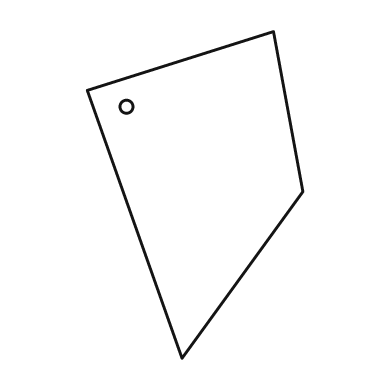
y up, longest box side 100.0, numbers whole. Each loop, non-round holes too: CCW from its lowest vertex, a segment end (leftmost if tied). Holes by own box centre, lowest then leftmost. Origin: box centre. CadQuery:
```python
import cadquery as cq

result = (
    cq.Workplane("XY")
    .moveTo(-4.0, -50.0)
    .lineTo(33.0, 1.0)
    .lineTo(24.0, 50.0)
    .lineTo(-33.0, 32.0)
    .close()
    .moveTo(-21.0, 27.0)
    .circle(2.0)
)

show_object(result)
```